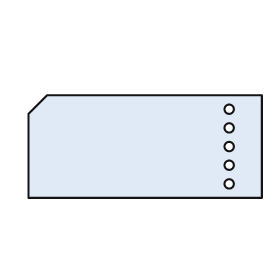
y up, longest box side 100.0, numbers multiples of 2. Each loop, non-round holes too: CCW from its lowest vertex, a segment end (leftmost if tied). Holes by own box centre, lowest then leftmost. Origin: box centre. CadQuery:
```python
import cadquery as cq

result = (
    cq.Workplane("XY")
    .moveTo(-50.0, -22.0)
    .lineTo(50.0, -22.0)
    .lineTo(50.0, 22.0)
    .lineTo(-42.0, 22.0)
    .lineTo(-50.0, 14.0)
    .close()
    .moveTo(36.0, -16.0)
    .circle(2.0)
    .moveTo(36.0, -8.0)
    .circle(2.0)
    .moveTo(36.0, 0.0)
    .circle(2.0)
    .moveTo(36.0, 8.0)
    .circle(2.0)
    .moveTo(36.0, 16.0)
    .circle(2.0)
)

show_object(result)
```